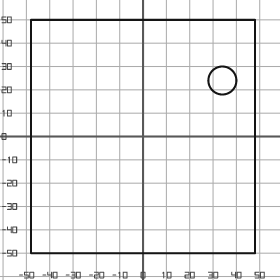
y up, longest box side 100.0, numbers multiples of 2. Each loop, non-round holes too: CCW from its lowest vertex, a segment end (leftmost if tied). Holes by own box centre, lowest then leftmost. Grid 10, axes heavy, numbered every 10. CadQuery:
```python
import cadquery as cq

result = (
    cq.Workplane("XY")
    .moveTo(-48.0, -50.0)
    .lineTo(48.0, -50.0)
    .lineTo(48.0, 50.0)
    .lineTo(-48.0, 50.0)
    .close()
    .moveTo(34.0, 24.0)
    .circle(6.0)
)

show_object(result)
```